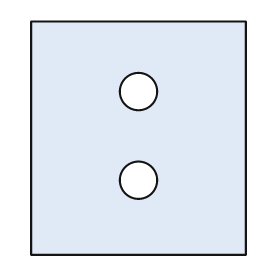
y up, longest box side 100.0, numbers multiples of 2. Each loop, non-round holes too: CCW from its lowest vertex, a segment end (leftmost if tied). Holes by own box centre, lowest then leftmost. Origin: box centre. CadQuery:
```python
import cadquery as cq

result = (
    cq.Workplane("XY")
    .moveTo(-46.0, -50.0)
    .lineTo(46.0, -50.0)
    .lineTo(46.0, 50.0)
    .lineTo(-46.0, 50.0)
    .close()
    .moveTo(0.0, -18.0)
    .circle(8.0)
    .moveTo(0.0, 20.0)
    .circle(8.0)
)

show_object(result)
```